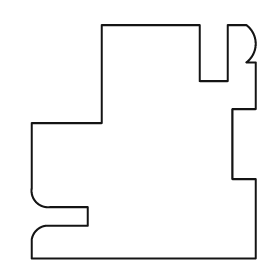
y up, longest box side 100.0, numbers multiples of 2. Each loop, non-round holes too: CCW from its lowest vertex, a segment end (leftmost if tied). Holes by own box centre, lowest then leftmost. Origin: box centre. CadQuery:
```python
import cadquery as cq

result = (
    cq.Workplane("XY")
    .moveTo(-48.0, -50.0)
    .lineTo(48.0, -50.0)
    .lineTo(48.0, -16.0)
    .lineTo(38.0, -16.0)
    .lineTo(38.0, 14.0)
    .lineTo(48.0, 14.0)
    .lineTo(48.0, 34.0)
    .lineTo(44.0, 34.0)
    .threePointArc((48.0, 42.0), (44.0, 50.0))
    .lineTo(36.0, 50.0)
    .lineTo(36.0, 26.0)
    .lineTo(24.0, 26.0)
    .lineTo(24.0, 50.0)
    .lineTo(-18.0, 50.0)
    .lineTo(-18.0, 8.0)
    .lineTo(-48.0, 8.0)
    .lineTo(-48.0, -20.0)
    .threePointArc((-46.0, -26.0), (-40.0, -28.0))
    .lineTo(-24.0, -28.0)
    .lineTo(-24.0, -36.0)
    .lineTo(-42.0, -36.0)
    .threePointArc((-46.0, -38.0), (-48.0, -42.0))
    .close()
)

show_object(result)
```